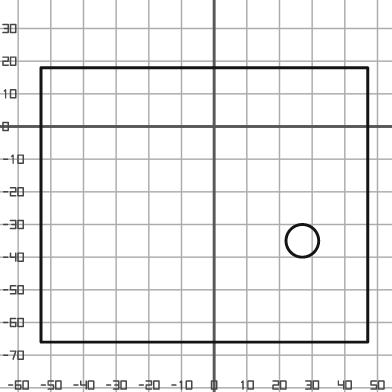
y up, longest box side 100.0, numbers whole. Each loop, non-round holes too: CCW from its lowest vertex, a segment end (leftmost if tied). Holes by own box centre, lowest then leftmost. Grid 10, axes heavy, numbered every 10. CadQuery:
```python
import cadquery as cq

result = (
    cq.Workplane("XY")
    .moveTo(-53.0, -66.0)
    .lineTo(47.0, -66.0)
    .lineTo(47.0, 18.0)
    .lineTo(-53.0, 18.0)
    .close()
    .moveTo(27.0, -35.0)
    .circle(5.0)
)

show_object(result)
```